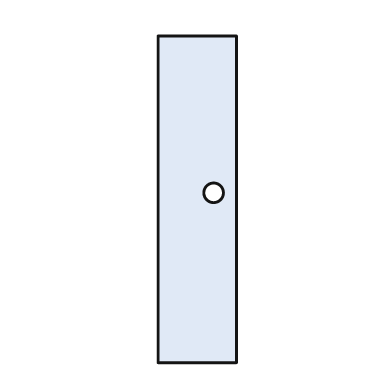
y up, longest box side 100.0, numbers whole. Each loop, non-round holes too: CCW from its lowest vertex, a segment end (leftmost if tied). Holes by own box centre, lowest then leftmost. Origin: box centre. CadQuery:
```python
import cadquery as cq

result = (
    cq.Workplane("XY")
    .moveTo(-12.0, -50.0)
    .lineTo(12.0, -50.0)
    .lineTo(12.0, 50.0)
    .lineTo(-12.0, 50.0)
    .close()
    .moveTo(5.0, 2.0)
    .circle(3.0)
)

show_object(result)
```